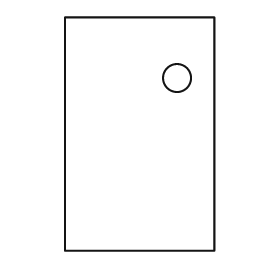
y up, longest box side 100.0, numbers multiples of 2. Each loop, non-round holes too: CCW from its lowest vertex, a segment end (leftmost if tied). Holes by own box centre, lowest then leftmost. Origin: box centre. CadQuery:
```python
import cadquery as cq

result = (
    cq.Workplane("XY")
    .moveTo(-32.0, -50.0)
    .lineTo(32.0, -50.0)
    .lineTo(32.0, 50.0)
    .lineTo(-32.0, 50.0)
    .close()
    .moveTo(16.0, 24.0)
    .circle(6.0)
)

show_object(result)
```